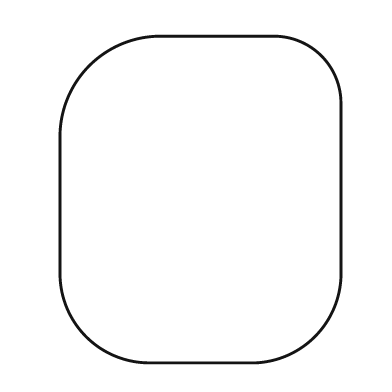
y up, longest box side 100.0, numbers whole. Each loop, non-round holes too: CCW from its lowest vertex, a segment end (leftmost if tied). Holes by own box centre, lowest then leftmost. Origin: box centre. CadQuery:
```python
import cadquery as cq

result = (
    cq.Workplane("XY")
    .moveTo(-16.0, -50.0)
    .lineTo(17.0, -50.0)
    .threePointArc((35.0, -42.0), (43.0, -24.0))
    .lineTo(43.0, 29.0)
    .threePointArc((37.0, 44.0), (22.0, 50.0))
    .lineTo(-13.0, 50.0)
    .threePointArc((-34.0, 41.0), (-43.0, 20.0))
    .lineTo(-43.0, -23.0)
    .threePointArc((-35.0, -42.0), (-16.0, -50.0))
    .close()
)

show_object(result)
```